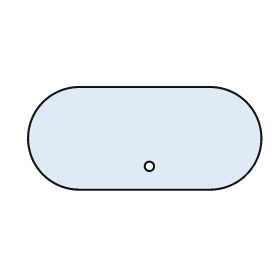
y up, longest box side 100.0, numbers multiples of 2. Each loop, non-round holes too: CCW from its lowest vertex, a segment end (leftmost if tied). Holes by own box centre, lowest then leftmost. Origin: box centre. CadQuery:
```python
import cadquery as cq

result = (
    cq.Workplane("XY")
    .moveTo(-28.0, -22.0)
    .lineTo(28.0, -22.0)
    .threePointArc((50.0, 0.0), (28.0, 22.0))
    .lineTo(-28.0, 22.0)
    .threePointArc((-50.0, 0.0), (-28.0, -22.0))
    .close()
    .moveTo(2.0, -12.0)
    .circle(2.0)
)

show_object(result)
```